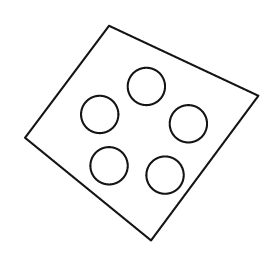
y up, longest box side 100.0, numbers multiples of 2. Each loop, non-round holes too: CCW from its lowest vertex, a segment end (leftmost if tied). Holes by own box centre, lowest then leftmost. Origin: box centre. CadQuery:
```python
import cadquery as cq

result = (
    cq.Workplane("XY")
    .moveTo(4.0, -46.0)
    .lineTo(50.0, 16.0)
    .lineTo(-14.0, 46.0)
    .lineTo(-50.0, -2.0)
    .close()
    .moveTo(10.0, -18.0)
    .circle(8.0)
    .moveTo(-14.0, -14.0)
    .circle(8.0)
    .moveTo(20.0, 4.0)
    .circle(8.0)
    .moveTo(-18.0, 8.0)
    .circle(8.0)
    .moveTo(2.0, 20.0)
    .circle(8.0)
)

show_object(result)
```